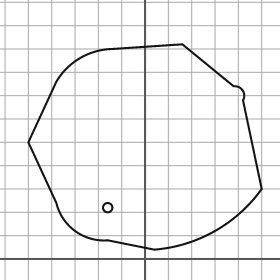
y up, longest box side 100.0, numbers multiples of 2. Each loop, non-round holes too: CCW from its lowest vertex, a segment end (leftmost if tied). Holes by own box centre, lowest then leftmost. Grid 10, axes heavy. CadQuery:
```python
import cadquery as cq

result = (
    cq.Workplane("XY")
    .moveTo(4.0, 4.0)
    .threePointArc((30.0, 12.0), (50.0, 30.0))
    .lineTo(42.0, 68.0)
    .threePointArc((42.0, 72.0), (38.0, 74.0))
    .lineTo(16.0, 92.0)
    .lineTo(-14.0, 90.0)
    .threePointArc((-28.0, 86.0), (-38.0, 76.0))
    .lineTo(-50.0, 50.0)
    .lineTo(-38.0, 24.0)
    .threePointArc((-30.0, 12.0), (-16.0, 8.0))
    .close()
    .moveTo(-16.0, 22.0)
    .circle(2.0)
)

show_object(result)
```